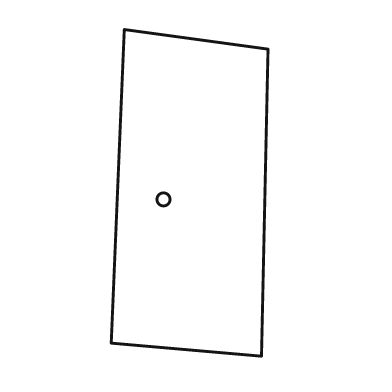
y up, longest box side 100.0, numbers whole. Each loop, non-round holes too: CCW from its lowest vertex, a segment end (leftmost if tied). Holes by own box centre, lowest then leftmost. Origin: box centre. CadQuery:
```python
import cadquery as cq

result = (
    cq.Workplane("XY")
    .moveTo(22.0, -50.0)
    .lineTo(24.0, 44.0)
    .lineTo(-20.0, 50.0)
    .lineTo(-24.0, -46.0)
    .close()
    .moveTo(-8.0, -2.0)
    .circle(2.0)
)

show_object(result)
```